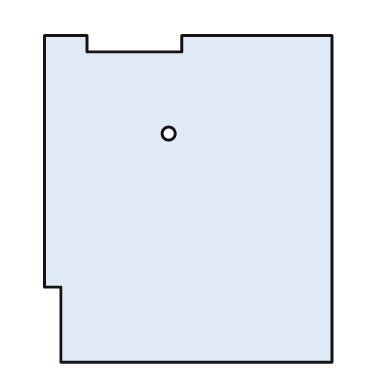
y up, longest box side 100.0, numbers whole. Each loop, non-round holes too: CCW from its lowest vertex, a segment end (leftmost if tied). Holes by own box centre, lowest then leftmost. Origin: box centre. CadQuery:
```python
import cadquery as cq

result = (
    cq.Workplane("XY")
    .moveTo(-39.0, -50.0)
    .lineTo(44.0, -50.0)
    .lineTo(44.0, 50.0)
    .lineTo(-2.0, 50.0)
    .lineTo(-2.0, 45.0)
    .lineTo(-31.0, 45.0)
    .lineTo(-31.0, 50.0)
    .lineTo(-44.0, 50.0)
    .lineTo(-44.0, -27.0)
    .lineTo(-39.0, -27.0)
    .close()
    .moveTo(-6.0, 20.0)
    .circle(2.0)
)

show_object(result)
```